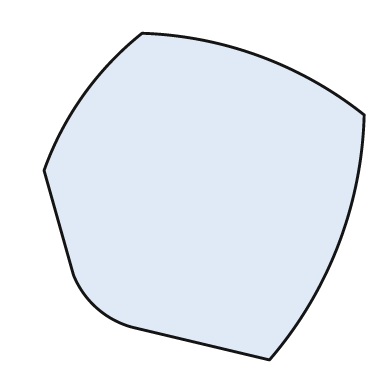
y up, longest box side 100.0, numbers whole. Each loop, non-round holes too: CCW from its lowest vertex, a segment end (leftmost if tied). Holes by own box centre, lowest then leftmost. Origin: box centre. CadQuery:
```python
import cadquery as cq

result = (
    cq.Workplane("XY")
    .moveTo(20.0, -50.0)
    .threePointArc((41.0, -15.0), (49.0, 25.0))
    .threePointArc((17.0, 43.0), (-19.0, 50.0))
    .threePointArc((-37.0, 31.0), (-49.0, 8.0))
    .lineTo(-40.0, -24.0)
    .threePointArc((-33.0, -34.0), (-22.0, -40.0))
    .close()
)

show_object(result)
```